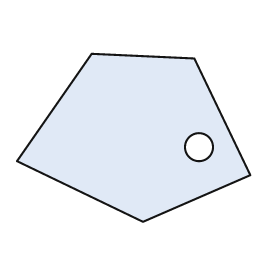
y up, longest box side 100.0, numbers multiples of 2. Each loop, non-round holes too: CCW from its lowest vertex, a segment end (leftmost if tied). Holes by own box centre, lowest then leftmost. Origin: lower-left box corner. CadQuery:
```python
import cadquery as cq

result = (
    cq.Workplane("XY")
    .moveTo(54.0, 0.0)
    .lineTo(100.0, 20.0)
    .lineTo(76.0, 70.0)
    .lineTo(32.0, 72.0)
    .lineTo(0.0, 26.0)
    .close()
    .moveTo(78.0, 32.0)
    .circle(6.0)
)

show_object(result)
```